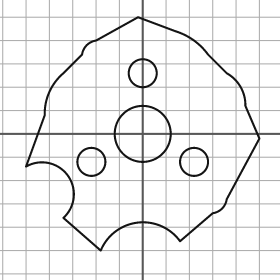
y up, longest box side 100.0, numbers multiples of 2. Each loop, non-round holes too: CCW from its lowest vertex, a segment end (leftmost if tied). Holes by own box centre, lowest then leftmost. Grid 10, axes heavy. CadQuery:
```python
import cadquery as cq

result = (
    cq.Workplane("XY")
    .moveTo(-18.0, -50.0)
    .threePointArc((-2.0, -38.0), (16.0, -46.0))
    .lineTo(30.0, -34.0)
    .threePointArc((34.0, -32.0), (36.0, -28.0))
    .lineTo(50.0, -2.0)
    .lineTo(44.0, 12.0)
    .threePointArc((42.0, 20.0), (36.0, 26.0))
    .lineTo(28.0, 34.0)
    .threePointArc((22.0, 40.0), (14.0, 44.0))
    .lineTo(-2.0, 50.0)
    .lineTo(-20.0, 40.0)
    .threePointArc((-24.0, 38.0), (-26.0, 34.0))
    .lineTo(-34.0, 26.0)
    .threePointArc((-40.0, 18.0), (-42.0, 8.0))
    .lineTo(-50.0, -14.0)
    .threePointArc((-32.0, -18.0), (-34.0, -36.0))
    .close()
    .moveTo(-22.0, -12.0)
    .circle(6.0)
    .moveTo(22.0, -12.0)
    .circle(6.0)
    .moveTo(0.0, 0.0)
    .circle(12.0)
    .moveTo(0.0, 26.0)
    .circle(6.0)
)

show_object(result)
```